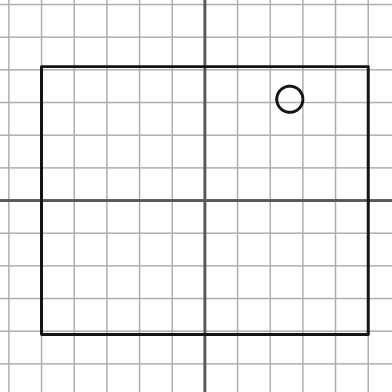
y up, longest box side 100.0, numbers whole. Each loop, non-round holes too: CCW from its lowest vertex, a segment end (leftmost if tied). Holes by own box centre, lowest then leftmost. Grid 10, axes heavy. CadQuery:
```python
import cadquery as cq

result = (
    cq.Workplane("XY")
    .moveTo(-50.0, -41.0)
    .lineTo(50.0, -41.0)
    .lineTo(50.0, 41.0)
    .lineTo(-50.0, 41.0)
    .close()
    .moveTo(26.0, 31.0)
    .circle(4.0)
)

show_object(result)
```